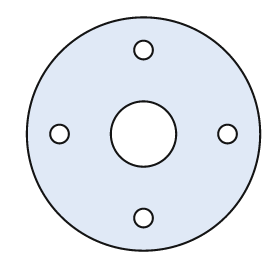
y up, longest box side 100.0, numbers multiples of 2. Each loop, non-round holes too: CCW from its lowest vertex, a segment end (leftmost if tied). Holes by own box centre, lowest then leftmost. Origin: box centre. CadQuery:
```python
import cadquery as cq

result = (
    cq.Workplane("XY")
    .moveTo(0.0, 0.0)
    .circle(50.0)
    .moveTo(0.0, -36.0)
    .circle(4.0)
    .moveTo(-36.0, 0.0)
    .circle(4.0)
    .moveTo(0.0, 0.0)
    .circle(14.0)
    .moveTo(36.0, 0.0)
    .circle(4.0)
    .moveTo(0.0, 36.0)
    .circle(4.0)
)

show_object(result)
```